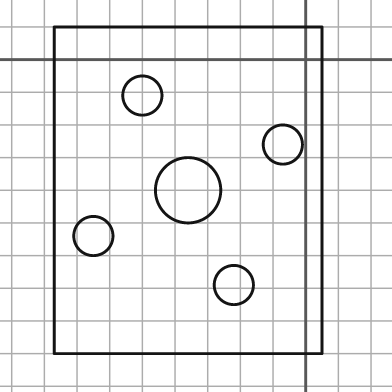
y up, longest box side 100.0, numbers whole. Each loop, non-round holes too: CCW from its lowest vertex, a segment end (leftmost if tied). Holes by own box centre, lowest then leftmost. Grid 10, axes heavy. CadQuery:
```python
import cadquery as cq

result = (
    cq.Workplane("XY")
    .moveTo(-77.0, -90.0)
    .lineTo(5.0, -90.0)
    .lineTo(5.0, 10.0)
    .lineTo(-77.0, 10.0)
    .close()
    .moveTo(-22.0, -69.0)
    .circle(6.0)
    .moveTo(-65.0, -54.0)
    .circle(6.0)
    .moveTo(-36.0, -40.0)
    .circle(10.0)
    .moveTo(-7.0, -26.0)
    .circle(6.0)
    .moveTo(-50.0, -11.0)
    .circle(6.0)
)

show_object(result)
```